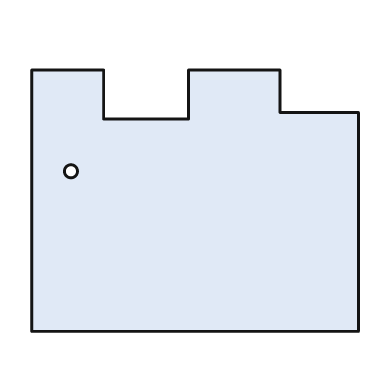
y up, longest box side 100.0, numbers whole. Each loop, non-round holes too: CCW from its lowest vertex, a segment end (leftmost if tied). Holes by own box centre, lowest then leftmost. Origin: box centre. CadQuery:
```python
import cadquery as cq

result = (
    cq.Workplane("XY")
    .moveTo(-50.0, -40.0)
    .lineTo(50.0, -40.0)
    .lineTo(50.0, 27.0)
    .lineTo(26.0, 27.0)
    .lineTo(26.0, 40.0)
    .lineTo(-2.0, 40.0)
    .lineTo(-2.0, 25.0)
    .lineTo(-28.0, 25.0)
    .lineTo(-28.0, 40.0)
    .lineTo(-50.0, 40.0)
    .close()
    .moveTo(-38.0, 9.0)
    .circle(2.0)
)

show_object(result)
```